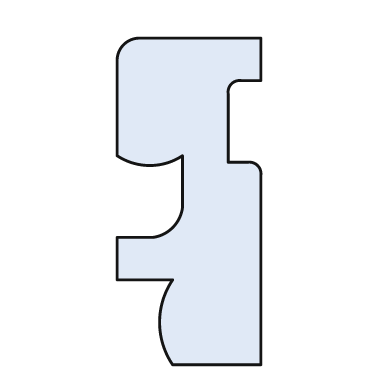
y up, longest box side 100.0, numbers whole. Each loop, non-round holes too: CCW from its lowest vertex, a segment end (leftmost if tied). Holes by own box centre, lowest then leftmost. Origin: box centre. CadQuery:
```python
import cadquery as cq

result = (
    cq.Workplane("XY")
    .moveTo(-5.0, -50.0)
    .lineTo(22.0, -50.0)
    .lineTo(22.0, 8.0)
    .threePointArc((21.0, 11.0), (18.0, 12.0))
    .lineTo(12.0, 12.0)
    .lineTo(12.0, 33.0)
    .threePointArc((13.0, 36.0), (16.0, 37.0))
    .lineTo(22.0, 37.0)
    .lineTo(22.0, 50.0)
    .lineTo(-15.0, 50.0)
    .threePointArc((-20.0, 48.0), (-22.0, 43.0))
    .lineTo(-22.0, 14.0)
    .threePointArc((-12.0, 11.0), (-2.0, 14.0))
    .lineTo(-2.0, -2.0)
    .threePointArc((-5.0, -8.0), (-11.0, -11.0))
    .lineTo(-22.0, -11.0)
    .lineTo(-22.0, -24.0)
    .lineTo(-5.0, -24.0)
    .threePointArc((-9.0, -37.0), (-5.0, -50.0))
    .close()
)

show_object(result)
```